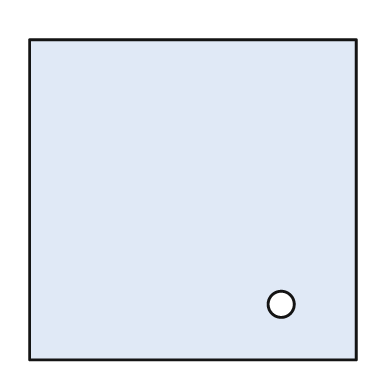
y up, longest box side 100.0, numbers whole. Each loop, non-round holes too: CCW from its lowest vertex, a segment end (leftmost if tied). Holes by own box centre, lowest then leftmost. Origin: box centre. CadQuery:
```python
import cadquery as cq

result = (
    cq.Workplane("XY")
    .moveTo(-50.0, -49.0)
    .lineTo(50.0, -49.0)
    .lineTo(50.0, 49.0)
    .lineTo(-50.0, 49.0)
    .close()
    .moveTo(27.0, -32.0)
    .circle(4.0)
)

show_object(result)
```